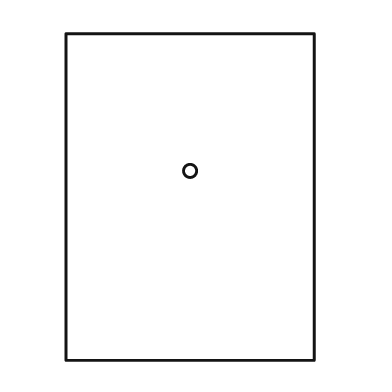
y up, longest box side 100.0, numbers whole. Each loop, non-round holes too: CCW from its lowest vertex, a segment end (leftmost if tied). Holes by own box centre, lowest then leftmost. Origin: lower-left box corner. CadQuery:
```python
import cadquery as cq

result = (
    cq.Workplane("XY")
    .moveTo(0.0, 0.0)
    .lineTo(76.0, 0.0)
    .lineTo(76.0, 100.0)
    .lineTo(0.0, 100.0)
    .close()
    .moveTo(38.0, 58.0)
    .circle(2.0)
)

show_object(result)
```